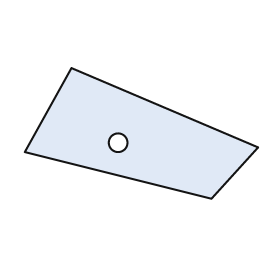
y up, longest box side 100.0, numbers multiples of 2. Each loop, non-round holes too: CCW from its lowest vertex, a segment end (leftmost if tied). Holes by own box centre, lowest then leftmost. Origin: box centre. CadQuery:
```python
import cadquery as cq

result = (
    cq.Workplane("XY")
    .moveTo(30.0, -28.0)
    .lineTo(50.0, -6.0)
    .lineTo(-30.0, 28.0)
    .lineTo(-50.0, -8.0)
    .close()
    .moveTo(-10.0, -4.0)
    .circle(4.0)
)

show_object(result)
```